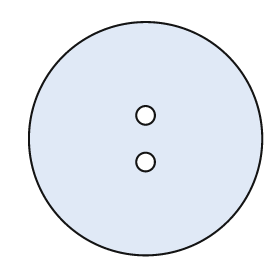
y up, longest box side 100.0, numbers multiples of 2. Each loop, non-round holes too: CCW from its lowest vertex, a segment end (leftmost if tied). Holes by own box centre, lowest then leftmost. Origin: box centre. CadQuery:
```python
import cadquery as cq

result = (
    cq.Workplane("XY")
    .moveTo(0.0, 0.0)
    .circle(50.0)
    .moveTo(0.0, -10.0)
    .circle(4.0)
    .moveTo(0.0, 10.0)
    .circle(4.0)
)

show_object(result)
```